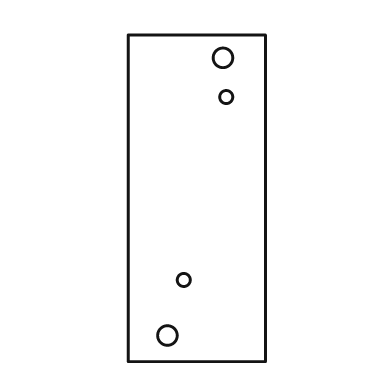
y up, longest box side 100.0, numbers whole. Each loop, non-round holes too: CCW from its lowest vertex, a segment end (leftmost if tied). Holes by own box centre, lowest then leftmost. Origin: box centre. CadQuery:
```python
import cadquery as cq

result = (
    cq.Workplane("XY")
    .moveTo(-21.0, -50.0)
    .lineTo(21.0, -50.0)
    .lineTo(21.0, 50.0)
    .lineTo(-21.0, 50.0)
    .close()
    .moveTo(-9.0, -42.0)
    .circle(3.0)
    .moveTo(-4.0, -25.0)
    .circle(2.0)
    .moveTo(9.0, 31.0)
    .circle(2.0)
    .moveTo(8.0, 43.0)
    .circle(3.0)
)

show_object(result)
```